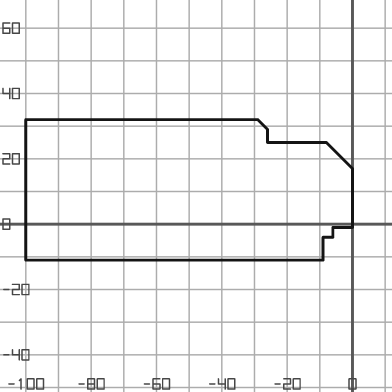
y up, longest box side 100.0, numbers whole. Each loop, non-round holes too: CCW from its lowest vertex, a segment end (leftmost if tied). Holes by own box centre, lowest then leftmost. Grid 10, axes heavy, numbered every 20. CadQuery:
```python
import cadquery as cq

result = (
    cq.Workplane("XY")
    .moveTo(-100.0, -11.0)
    .lineTo(-9.0, -11.0)
    .lineTo(-9.0, -4.0)
    .lineTo(-6.0, -4.0)
    .lineTo(-6.0, -1.0)
    .lineTo(0.0, -1.0)
    .lineTo(0.0, 17.0)
    .lineTo(-8.0, 25.0)
    .lineTo(-26.0, 25.0)
    .lineTo(-26.0, 29.0)
    .lineTo(-29.0, 32.0)
    .lineTo(-100.0, 32.0)
    .close()
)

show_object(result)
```